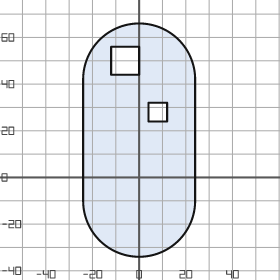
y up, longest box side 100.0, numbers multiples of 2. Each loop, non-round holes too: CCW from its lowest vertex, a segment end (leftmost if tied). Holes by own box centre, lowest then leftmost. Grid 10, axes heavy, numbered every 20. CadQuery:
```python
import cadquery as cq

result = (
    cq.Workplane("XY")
    .moveTo(-24.0, -10.0)
    .threePointArc((0.0, -34.0), (24.0, -10.0))
    .lineTo(24.0, 42.0)
    .threePointArc((0.0, 66.0), (-24.0, 42.0))
    .close()
    .moveTo(4.0, 24.0)
    .lineTo(12.0, 24.0)
    .lineTo(12.0, 32.0)
    .lineTo(4.0, 32.0)
    .close()
    .moveTo(-12.0, 44.0)
    .lineTo(0.0, 44.0)
    .lineTo(0.0, 56.0)
    .lineTo(-12.0, 56.0)
    .close()
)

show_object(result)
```